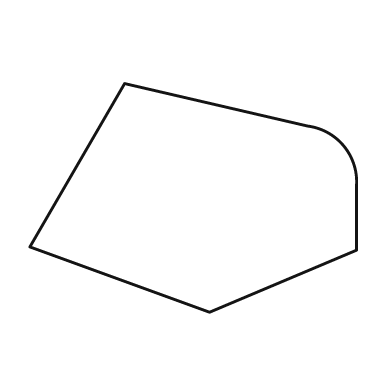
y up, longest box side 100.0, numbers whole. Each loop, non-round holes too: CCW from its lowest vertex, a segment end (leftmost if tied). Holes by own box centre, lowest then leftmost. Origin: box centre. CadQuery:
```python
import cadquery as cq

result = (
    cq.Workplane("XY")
    .moveTo(5.0, -35.0)
    .lineTo(50.0, -16.0)
    .lineTo(50.0, 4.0)
    .threePointArc((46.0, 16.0), (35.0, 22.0))
    .lineTo(-21.0, 35.0)
    .lineTo(-50.0, -15.0)
    .close()
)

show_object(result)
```